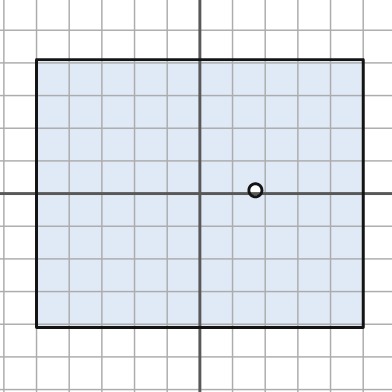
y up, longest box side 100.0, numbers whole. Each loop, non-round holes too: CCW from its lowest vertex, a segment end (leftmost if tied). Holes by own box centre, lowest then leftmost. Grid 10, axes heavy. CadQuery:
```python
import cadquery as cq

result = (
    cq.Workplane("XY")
    .moveTo(-50.0, -41.0)
    .lineTo(50.0, -41.0)
    .lineTo(50.0, 41.0)
    .lineTo(-50.0, 41.0)
    .close()
    .moveTo(17.0, 1.0)
    .circle(2.0)
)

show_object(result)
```